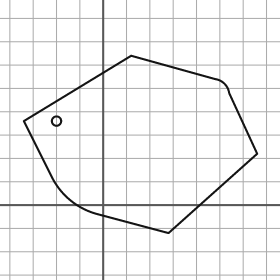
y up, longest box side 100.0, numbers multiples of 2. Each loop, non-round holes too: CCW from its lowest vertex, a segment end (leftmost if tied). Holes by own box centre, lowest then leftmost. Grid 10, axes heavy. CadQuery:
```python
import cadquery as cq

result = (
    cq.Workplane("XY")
    .moveTo(28.0, -12.0)
    .lineTo(66.0, 22.0)
    .lineTo(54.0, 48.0)
    .threePointArc((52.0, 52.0), (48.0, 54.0))
    .lineTo(12.0, 64.0)
    .lineTo(-34.0, 36.0)
    .lineTo(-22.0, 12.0)
    .threePointArc((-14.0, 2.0), (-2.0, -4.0))
    .close()
    .moveTo(-20.0, 36.0)
    .circle(2.0)
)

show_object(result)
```